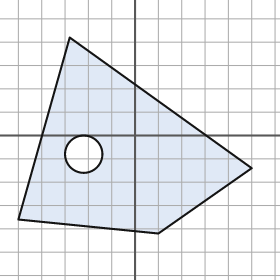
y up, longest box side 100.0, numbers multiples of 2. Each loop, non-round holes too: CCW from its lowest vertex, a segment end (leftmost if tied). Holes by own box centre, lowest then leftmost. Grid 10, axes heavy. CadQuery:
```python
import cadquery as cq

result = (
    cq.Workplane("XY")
    .moveTo(10.0, -42.0)
    .lineTo(50.0, -14.0)
    .lineTo(-28.0, 42.0)
    .lineTo(-50.0, -36.0)
    .close()
    .moveTo(-22.0, -8.0)
    .circle(8.0)
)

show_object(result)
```